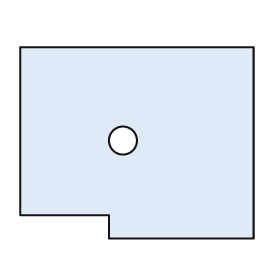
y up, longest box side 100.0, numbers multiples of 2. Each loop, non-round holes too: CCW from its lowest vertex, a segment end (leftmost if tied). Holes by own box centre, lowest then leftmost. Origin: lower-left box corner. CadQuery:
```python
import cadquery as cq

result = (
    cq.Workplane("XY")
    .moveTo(38.0, 0.0)
    .lineTo(100.0, 0.0)
    .lineTo(100.0, 82.0)
    .lineTo(0.0, 82.0)
    .lineTo(0.0, 10.0)
    .lineTo(38.0, 10.0)
    .close()
    .moveTo(44.0, 42.0)
    .circle(6.0)
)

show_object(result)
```